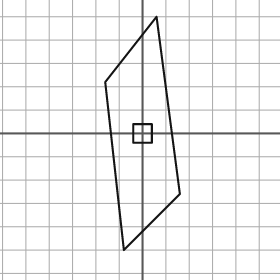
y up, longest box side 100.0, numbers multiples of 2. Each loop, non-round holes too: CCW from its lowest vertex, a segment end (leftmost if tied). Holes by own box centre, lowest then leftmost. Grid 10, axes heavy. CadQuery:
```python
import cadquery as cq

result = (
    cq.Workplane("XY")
    .moveTo(-8.0, -50.0)
    .lineTo(16.0, -26.0)
    .lineTo(6.0, 50.0)
    .lineTo(-16.0, 22.0)
    .close()
    .moveTo(-4.0, -4.0)
    .lineTo(4.0, -4.0)
    .lineTo(4.0, 4.0)
    .lineTo(-4.0, 4.0)
    .close()
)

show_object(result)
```